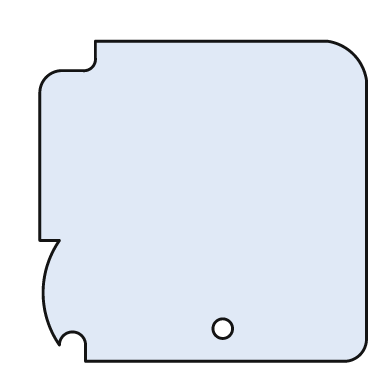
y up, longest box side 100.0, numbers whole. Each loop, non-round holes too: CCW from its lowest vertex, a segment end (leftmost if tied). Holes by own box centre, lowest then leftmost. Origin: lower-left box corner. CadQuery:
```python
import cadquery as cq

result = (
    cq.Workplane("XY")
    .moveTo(14.0, 0.0)
    .lineTo(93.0, 0.0)
    .threePointArc((98.0, 2.0), (100.0, 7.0))
    .lineTo(100.0, 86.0)
    .threePointArc((96.0, 94.0), (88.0, 98.0))
    .lineTo(17.0, 98.0)
    .lineTo(17.0, 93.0)
    .threePointArc((16.0, 90.0), (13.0, 89.0))
    .lineTo(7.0, 89.0)
    .threePointArc((2.0, 87.0), (0.0, 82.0))
    .lineTo(0.0, 37.0)
    .lineTo(6.0, 37.0)
    .threePointArc((1.0, 21.0), (6.0, 5.0))
    .threePointArc((10.0, 9.0), (14.0, 5.0))
    .close()
    .moveTo(56.0, 10.0)
    .circle(3.0)
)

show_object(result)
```